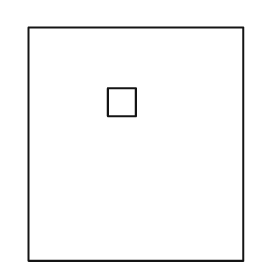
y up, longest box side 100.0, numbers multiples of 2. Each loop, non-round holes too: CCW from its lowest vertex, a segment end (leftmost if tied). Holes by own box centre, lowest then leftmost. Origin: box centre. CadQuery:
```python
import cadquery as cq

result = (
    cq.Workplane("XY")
    .moveTo(-46.0, -50.0)
    .lineTo(46.0, -50.0)
    .lineTo(46.0, 50.0)
    .lineTo(-46.0, 50.0)
    .close()
    .moveTo(-12.0, 12.0)
    .lineTo(0.0, 12.0)
    .lineTo(0.0, 24.0)
    .lineTo(-12.0, 24.0)
    .close()
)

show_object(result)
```